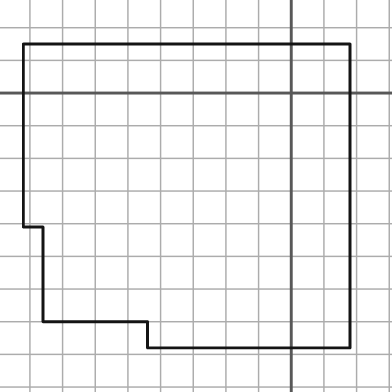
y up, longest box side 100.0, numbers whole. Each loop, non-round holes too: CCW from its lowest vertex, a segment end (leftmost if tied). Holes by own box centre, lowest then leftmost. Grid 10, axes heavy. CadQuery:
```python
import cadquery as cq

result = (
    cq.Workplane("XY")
    .moveTo(-44.0, -78.0)
    .lineTo(18.0, -78.0)
    .lineTo(18.0, 15.0)
    .lineTo(-82.0, 15.0)
    .lineTo(-82.0, -41.0)
    .lineTo(-76.0, -41.0)
    .lineTo(-76.0, -70.0)
    .lineTo(-44.0, -70.0)
    .close()
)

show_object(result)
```